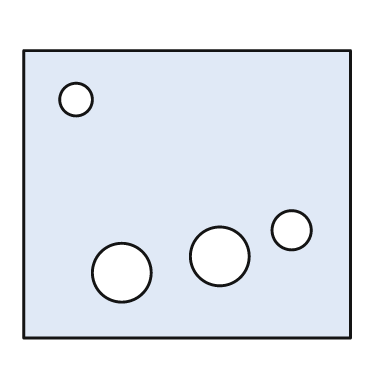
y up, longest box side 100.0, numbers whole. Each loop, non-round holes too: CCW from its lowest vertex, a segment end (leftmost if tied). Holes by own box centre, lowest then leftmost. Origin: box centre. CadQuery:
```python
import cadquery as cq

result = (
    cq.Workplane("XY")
    .moveTo(-50.0, -44.0)
    .lineTo(50.0, -44.0)
    .lineTo(50.0, 44.0)
    .lineTo(-50.0, 44.0)
    .close()
    .moveTo(-20.0, -24.0)
    .circle(9.0)
    .moveTo(10.0, -19.0)
    .circle(9.0)
    .moveTo(32.0, -11.0)
    .circle(6.0)
    .moveTo(-34.0, 29.0)
    .circle(5.0)
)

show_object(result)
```